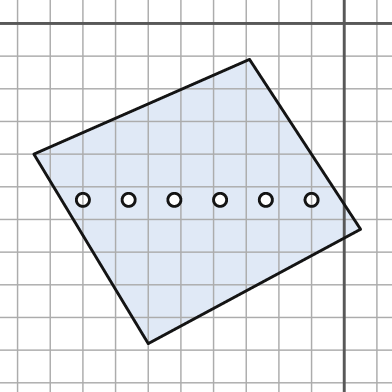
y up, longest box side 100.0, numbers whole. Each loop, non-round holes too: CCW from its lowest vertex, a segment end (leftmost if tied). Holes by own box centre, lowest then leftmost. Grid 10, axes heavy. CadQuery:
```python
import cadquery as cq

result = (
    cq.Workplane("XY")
    .moveTo(-60.0, -98.0)
    .lineTo(5.0, -63.0)
    .lineTo(-29.0, -11.0)
    .lineTo(-95.0, -40.0)
    .close()
    .moveTo(-80.0, -54.0)
    .circle(2.0)
    .moveTo(-66.0, -54.0)
    .circle(2.0)
    .moveTo(-52.0, -54.0)
    .circle(2.0)
    .moveTo(-38.0, -54.0)
    .circle(2.0)
    .moveTo(-24.0, -54.0)
    .circle(2.0)
    .moveTo(-10.0, -54.0)
    .circle(2.0)
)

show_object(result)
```